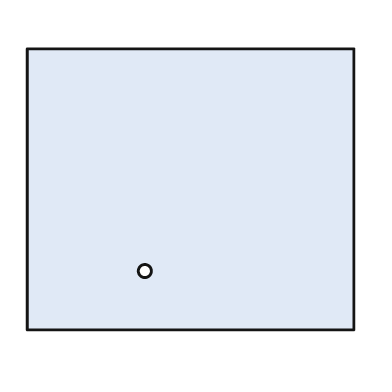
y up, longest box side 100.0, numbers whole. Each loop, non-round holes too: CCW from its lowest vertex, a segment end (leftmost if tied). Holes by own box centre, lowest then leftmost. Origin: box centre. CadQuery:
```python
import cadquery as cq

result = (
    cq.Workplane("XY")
    .moveTo(-50.0, -43.0)
    .lineTo(50.0, -43.0)
    .lineTo(50.0, 43.0)
    .lineTo(-50.0, 43.0)
    .close()
    .moveTo(-14.0, -25.0)
    .circle(2.0)
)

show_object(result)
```